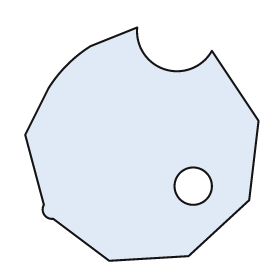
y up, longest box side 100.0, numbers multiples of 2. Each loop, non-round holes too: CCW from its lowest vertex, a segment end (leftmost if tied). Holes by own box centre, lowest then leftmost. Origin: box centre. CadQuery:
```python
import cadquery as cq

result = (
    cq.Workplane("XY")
    .moveTo(-14.0, -50.0)
    .lineTo(20.0, -48.0)
    .lineTo(46.0, -24.0)
    .lineTo(50.0, 10.0)
    .lineTo(30.0, 40.0)
    .threePointArc((10.0, 32.0), (-2.0, 50.0))
    .lineTo(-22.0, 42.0)
    .threePointArc((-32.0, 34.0), (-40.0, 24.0))
    .lineTo(-50.0, 4.0)
    .lineTo(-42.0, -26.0)
    .threePointArc((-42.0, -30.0), (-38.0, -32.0))
    .close()
    .moveTo(22.0, -18.0)
    .circle(8.0)
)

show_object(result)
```